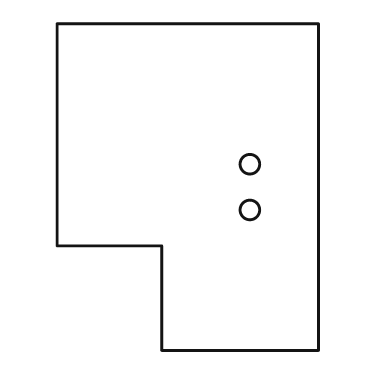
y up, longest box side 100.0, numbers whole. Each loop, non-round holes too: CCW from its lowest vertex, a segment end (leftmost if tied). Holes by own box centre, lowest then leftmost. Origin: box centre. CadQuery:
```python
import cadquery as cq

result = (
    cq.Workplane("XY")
    .moveTo(-8.0, -50.0)
    .lineTo(40.0, -50.0)
    .lineTo(40.0, 50.0)
    .lineTo(-40.0, 50.0)
    .lineTo(-40.0, -18.0)
    .lineTo(-8.0, -18.0)
    .close()
    .moveTo(19.0, -7.0)
    .circle(3.0)
    .moveTo(19.0, 7.0)
    .circle(3.0)
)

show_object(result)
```